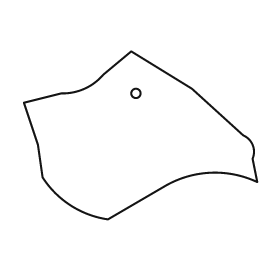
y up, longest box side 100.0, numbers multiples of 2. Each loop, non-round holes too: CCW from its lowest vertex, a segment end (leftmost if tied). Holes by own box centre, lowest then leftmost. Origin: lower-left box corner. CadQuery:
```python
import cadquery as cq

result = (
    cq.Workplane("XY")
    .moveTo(36.0, 0.0)
    .lineTo(60.0, 14.0)
    .threePointArc((80.0, 20.0), (100.0, 16.0))
    .lineTo(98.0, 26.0)
    .threePointArc((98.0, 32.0), (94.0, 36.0))
    .lineTo(72.0, 56.0)
    .lineTo(46.0, 72.0)
    .lineTo(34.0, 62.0)
    .threePointArc((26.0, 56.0), (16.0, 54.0))
    .lineTo(0.0, 50.0)
    .lineTo(6.0, 32.0)
    .lineTo(8.0, 18.0)
    .threePointArc((20.0, 6.0), (36.0, 0.0))
    .close()
    .moveTo(48.0, 54.0)
    .circle(2.0)
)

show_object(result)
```